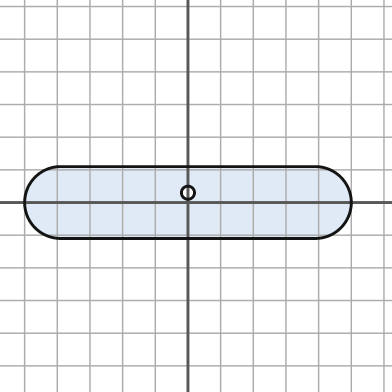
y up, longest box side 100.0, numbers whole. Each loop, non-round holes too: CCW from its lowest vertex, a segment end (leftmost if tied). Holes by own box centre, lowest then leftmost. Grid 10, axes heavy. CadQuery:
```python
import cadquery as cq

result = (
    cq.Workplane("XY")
    .moveTo(-39.0, -11.0)
    .lineTo(39.0, -11.0)
    .threePointArc((50.0, 0.0), (39.0, 11.0))
    .lineTo(-39.0, 11.0)
    .threePointArc((-50.0, 0.0), (-39.0, -11.0))
    .close()
    .moveTo(0.0, 3.0)
    .circle(2.0)
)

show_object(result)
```